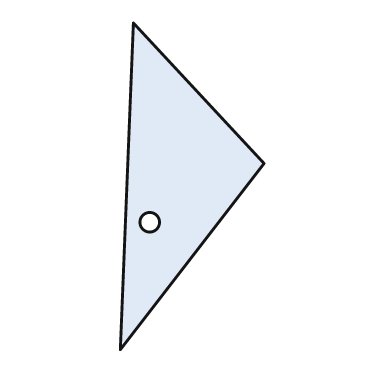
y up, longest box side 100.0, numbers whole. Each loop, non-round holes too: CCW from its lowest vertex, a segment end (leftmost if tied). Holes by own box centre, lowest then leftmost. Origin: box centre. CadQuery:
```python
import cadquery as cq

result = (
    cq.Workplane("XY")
    .moveTo(-22.0, -50.0)
    .lineTo(22.0, 7.0)
    .lineTo(-18.0, 50.0)
    .close()
    .moveTo(-13.0, -11.0)
    .circle(3.0)
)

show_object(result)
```